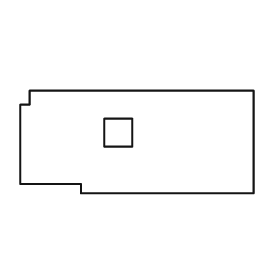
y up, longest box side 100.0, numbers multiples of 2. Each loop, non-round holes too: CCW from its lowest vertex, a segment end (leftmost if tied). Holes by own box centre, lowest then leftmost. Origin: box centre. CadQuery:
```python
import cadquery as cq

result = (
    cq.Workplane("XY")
    .moveTo(-24.0, -22.0)
    .lineTo(50.0, -22.0)
    .lineTo(50.0, 22.0)
    .lineTo(-46.0, 22.0)
    .lineTo(-46.0, 16.0)
    .lineTo(-50.0, 16.0)
    .lineTo(-50.0, -18.0)
    .lineTo(-24.0, -18.0)
    .close()
    .moveTo(-14.0, -2.0)
    .lineTo(-2.0, -2.0)
    .lineTo(-2.0, 10.0)
    .lineTo(-14.0, 10.0)
    .close()
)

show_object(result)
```